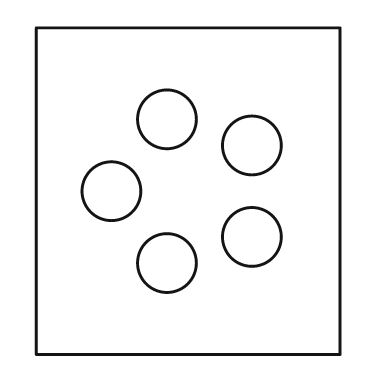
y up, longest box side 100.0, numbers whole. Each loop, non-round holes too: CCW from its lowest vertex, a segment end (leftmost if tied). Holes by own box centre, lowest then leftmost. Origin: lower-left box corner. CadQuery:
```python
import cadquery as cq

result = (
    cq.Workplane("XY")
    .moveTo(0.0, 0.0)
    .lineTo(93.0, 0.0)
    .lineTo(93.0, 100.0)
    .lineTo(0.0, 100.0)
    .close()
    .moveTo(40.0, 28.0)
    .circle(9.0)
    .moveTo(66.0, 36.0)
    .circle(9.0)
    .moveTo(23.0, 50.0)
    .circle(9.0)
    .moveTo(66.0, 64.0)
    .circle(9.0)
    .moveTo(40.0, 72.0)
    .circle(9.0)
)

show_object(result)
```